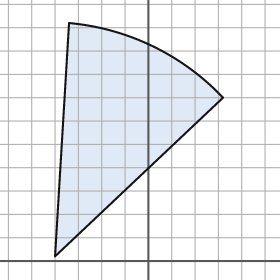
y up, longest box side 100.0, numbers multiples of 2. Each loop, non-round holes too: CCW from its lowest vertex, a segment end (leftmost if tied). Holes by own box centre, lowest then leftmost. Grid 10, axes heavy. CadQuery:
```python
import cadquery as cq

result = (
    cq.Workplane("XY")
    .moveTo(-40.0, 2.0)
    .lineTo(32.0, 70.0)
    .threePointArc((2.0, 92.0), (-34.0, 102.0))
    .close()
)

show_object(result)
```